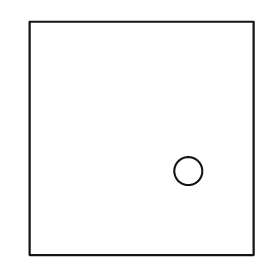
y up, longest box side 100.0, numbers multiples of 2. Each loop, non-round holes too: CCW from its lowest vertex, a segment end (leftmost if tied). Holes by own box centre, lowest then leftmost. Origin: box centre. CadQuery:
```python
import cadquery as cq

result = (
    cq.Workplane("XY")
    .moveTo(-48.0, -50.0)
    .lineTo(48.0, -50.0)
    .lineTo(48.0, 50.0)
    .lineTo(-48.0, 50.0)
    .close()
    .moveTo(20.0, -14.0)
    .circle(6.0)
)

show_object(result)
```